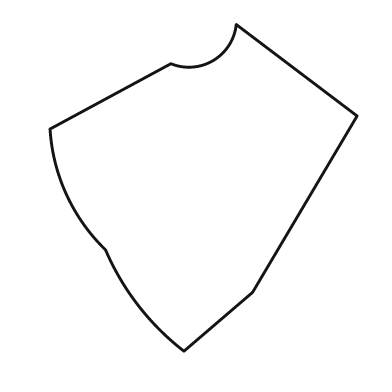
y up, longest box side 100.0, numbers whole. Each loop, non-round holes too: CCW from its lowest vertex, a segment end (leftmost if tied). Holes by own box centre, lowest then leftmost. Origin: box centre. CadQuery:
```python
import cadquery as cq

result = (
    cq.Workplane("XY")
    .moveTo(-6.0, -50.0)
    .lineTo(15.0, -32.0)
    .lineTo(47.0, 22.0)
    .lineTo(10.0, 50.0)
    .threePointArc((3.0, 39.0), (-10.0, 38.0))
    .lineTo(-47.0, 18.0)
    .threePointArc((-42.0, -2.0), (-30.0, -19.0))
    .threePointArc((-20.0, -36.0), (-6.0, -50.0))
    .close()
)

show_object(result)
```